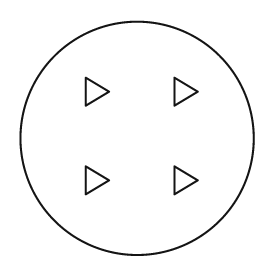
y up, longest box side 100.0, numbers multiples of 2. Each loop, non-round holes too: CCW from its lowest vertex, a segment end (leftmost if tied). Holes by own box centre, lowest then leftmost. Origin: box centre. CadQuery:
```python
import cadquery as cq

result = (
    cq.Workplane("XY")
    .moveTo(0.0, 0.0)
    .circle(50.0)
    .moveTo(-22.0, -24.0)
    .lineTo(-12.0, -18.0)
    .lineTo(-22.0, -12.0)
    .close()
    .moveTo(16.0, -24.0)
    .lineTo(26.0, -18.0)
    .lineTo(16.0, -12.0)
    .close()
    .moveTo(-22.0, 14.0)
    .lineTo(-12.0, 20.0)
    .lineTo(-22.0, 26.0)
    .close()
    .moveTo(16.0, 14.0)
    .lineTo(26.0, 20.0)
    .lineTo(16.0, 26.0)
    .close()
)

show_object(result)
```